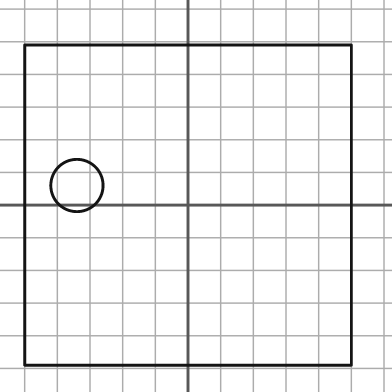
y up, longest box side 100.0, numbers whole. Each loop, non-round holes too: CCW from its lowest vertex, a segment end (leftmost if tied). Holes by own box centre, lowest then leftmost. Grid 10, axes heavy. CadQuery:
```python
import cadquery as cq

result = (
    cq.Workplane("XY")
    .moveTo(-50.0, -49.0)
    .lineTo(50.0, -49.0)
    .lineTo(50.0, 49.0)
    .lineTo(-50.0, 49.0)
    .close()
    .moveTo(-34.0, 6.0)
    .circle(8.0)
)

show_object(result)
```